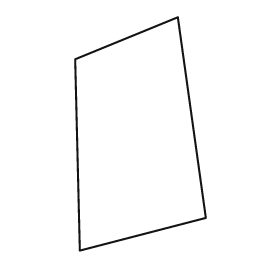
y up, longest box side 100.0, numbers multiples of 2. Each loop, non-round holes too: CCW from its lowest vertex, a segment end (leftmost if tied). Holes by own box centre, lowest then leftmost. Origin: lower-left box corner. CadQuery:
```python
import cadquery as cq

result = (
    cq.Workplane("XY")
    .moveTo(2.0, 0.0)
    .lineTo(56.0, 14.0)
    .lineTo(44.0, 100.0)
    .lineTo(0.0, 82.0)
    .close()
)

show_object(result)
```